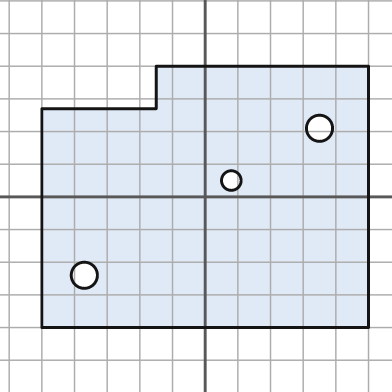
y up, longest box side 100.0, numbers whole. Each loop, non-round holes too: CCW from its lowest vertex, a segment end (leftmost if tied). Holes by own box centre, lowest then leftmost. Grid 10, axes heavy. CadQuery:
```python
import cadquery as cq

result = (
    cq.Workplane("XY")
    .moveTo(-50.0, -40.0)
    .lineTo(50.0, -40.0)
    .lineTo(50.0, 40.0)
    .lineTo(-15.0, 40.0)
    .lineTo(-15.0, 27.0)
    .lineTo(-50.0, 27.0)
    .close()
    .moveTo(-37.0, -24.0)
    .circle(4.0)
    .moveTo(8.0, 5.0)
    .circle(3.0)
    .moveTo(35.0, 21.0)
    .circle(4.0)
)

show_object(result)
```